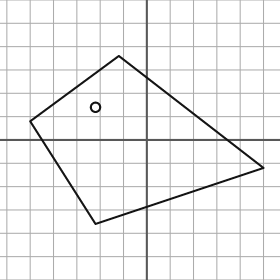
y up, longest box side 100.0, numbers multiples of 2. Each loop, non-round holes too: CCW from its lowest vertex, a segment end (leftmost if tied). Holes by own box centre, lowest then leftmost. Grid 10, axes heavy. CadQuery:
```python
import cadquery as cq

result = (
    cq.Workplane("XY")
    .moveTo(-22.0, -36.0)
    .lineTo(50.0, -12.0)
    .lineTo(-12.0, 36.0)
    .lineTo(-50.0, 8.0)
    .close()
    .moveTo(-22.0, 14.0)
    .circle(2.0)
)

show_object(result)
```